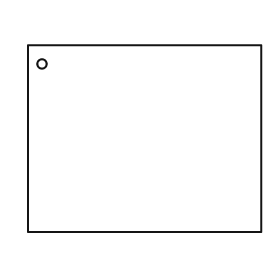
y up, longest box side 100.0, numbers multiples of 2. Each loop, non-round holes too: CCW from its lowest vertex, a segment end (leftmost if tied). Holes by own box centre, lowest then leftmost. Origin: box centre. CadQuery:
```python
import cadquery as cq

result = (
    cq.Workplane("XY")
    .moveTo(-50.0, -40.0)
    .lineTo(50.0, -40.0)
    .lineTo(50.0, 40.0)
    .lineTo(-50.0, 40.0)
    .close()
    .moveTo(-44.0, 32.0)
    .circle(2.0)
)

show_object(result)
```